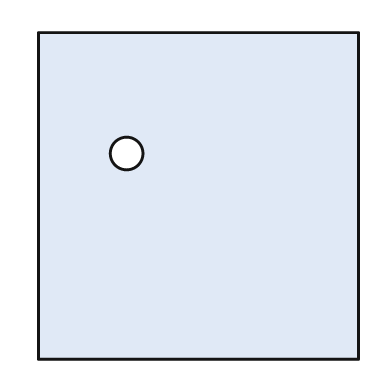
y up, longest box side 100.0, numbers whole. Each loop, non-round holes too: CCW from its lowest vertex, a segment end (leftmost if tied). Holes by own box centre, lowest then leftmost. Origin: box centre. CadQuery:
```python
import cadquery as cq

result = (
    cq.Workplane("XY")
    .moveTo(-49.0, -50.0)
    .lineTo(49.0, -50.0)
    .lineTo(49.0, 50.0)
    .lineTo(-49.0, 50.0)
    .close()
    .moveTo(-22.0, 13.0)
    .circle(5.0)
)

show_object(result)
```